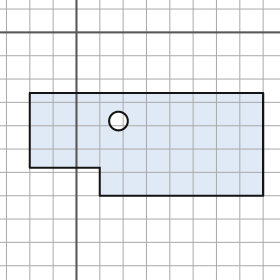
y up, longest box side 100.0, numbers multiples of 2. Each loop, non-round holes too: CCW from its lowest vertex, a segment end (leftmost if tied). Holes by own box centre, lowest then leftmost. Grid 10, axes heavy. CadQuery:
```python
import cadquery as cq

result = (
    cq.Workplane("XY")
    .moveTo(10.0, -70.0)
    .lineTo(80.0, -70.0)
    .lineTo(80.0, -26.0)
    .lineTo(-20.0, -26.0)
    .lineTo(-20.0, -58.0)
    .lineTo(10.0, -58.0)
    .close()
    .moveTo(18.0, -38.0)
    .circle(4.0)
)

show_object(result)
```